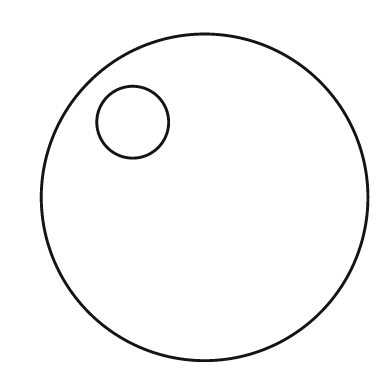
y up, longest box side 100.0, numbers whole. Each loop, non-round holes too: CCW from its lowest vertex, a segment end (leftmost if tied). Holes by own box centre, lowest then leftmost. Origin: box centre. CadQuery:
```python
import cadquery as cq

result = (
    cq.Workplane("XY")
    .moveTo(0.0, 0.0)
    .circle(50.0)
    .moveTo(-22.0, 23.0)
    .circle(11.0)
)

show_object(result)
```